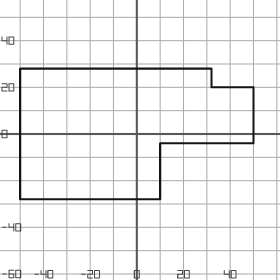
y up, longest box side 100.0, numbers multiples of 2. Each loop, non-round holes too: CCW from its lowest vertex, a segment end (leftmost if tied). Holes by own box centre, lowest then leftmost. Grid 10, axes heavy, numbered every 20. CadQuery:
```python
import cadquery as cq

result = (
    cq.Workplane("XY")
    .moveTo(-50.0, -28.0)
    .lineTo(10.0, -28.0)
    .lineTo(10.0, -4.0)
    .lineTo(50.0, -4.0)
    .lineTo(50.0, 20.0)
    .lineTo(32.0, 20.0)
    .lineTo(32.0, 28.0)
    .lineTo(-50.0, 28.0)
    .close()
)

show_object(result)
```